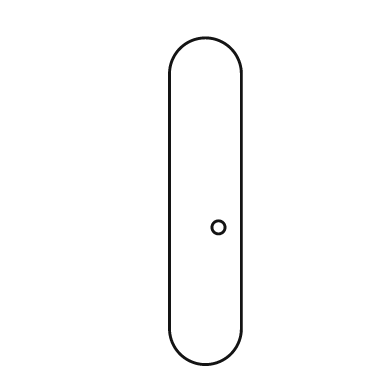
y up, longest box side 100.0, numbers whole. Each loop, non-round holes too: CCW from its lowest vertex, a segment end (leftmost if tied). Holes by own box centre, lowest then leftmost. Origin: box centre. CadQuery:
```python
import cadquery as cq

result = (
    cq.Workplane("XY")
    .moveTo(-11.0, -39.0)
    .threePointArc((0.0, -50.0), (11.0, -39.0))
    .lineTo(11.0, 39.0)
    .threePointArc((0.0, 50.0), (-11.0, 39.0))
    .close()
    .moveTo(4.0, -8.0)
    .circle(2.0)
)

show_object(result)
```